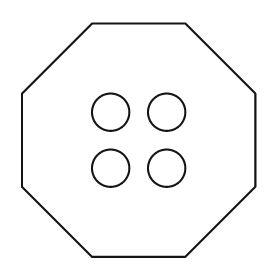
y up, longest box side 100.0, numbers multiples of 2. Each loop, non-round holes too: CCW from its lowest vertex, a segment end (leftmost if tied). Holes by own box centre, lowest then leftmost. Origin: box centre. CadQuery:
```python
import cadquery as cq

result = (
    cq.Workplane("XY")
    .moveTo(-20.0, -50.0)
    .lineTo(20.0, -50.0)
    .lineTo(50.0, -20.0)
    .lineTo(50.0, 20.0)
    .lineTo(20.0, 50.0)
    .lineTo(-20.0, 50.0)
    .lineTo(-50.0, 20.0)
    .lineTo(-50.0, -20.0)
    .close()
    .moveTo(-12.0, -12.0)
    .circle(8.0)
    .moveTo(12.0, -12.0)
    .circle(8.0)
    .moveTo(-12.0, 12.0)
    .circle(8.0)
    .moveTo(12.0, 12.0)
    .circle(8.0)
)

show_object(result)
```